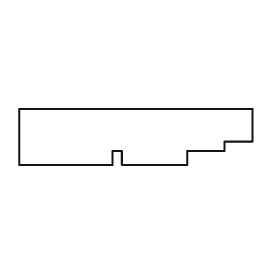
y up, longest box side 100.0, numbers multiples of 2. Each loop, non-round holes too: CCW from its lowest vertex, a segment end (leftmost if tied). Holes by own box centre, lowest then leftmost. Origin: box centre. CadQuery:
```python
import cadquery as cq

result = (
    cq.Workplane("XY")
    .moveTo(-50.0, -12.0)
    .lineTo(-10.0, -12.0)
    .lineTo(-10.0, -6.0)
    .lineTo(-6.0, -6.0)
    .lineTo(-6.0, -12.0)
    .lineTo(22.0, -12.0)
    .lineTo(22.0, -6.0)
    .lineTo(38.0, -6.0)
    .lineTo(38.0, -2.0)
    .lineTo(50.0, -2.0)
    .lineTo(50.0, 12.0)
    .lineTo(-50.0, 12.0)
    .close()
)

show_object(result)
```